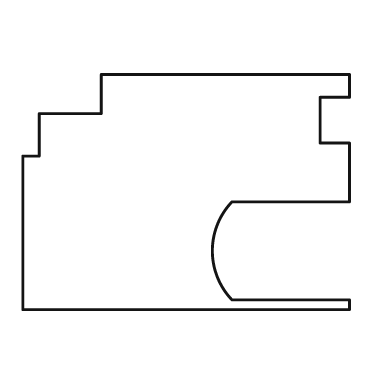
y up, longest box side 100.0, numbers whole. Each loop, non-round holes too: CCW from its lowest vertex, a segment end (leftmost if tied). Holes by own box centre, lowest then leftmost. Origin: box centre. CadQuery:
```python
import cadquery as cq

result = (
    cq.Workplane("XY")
    .moveTo(-50.0, -36.0)
    .lineTo(50.0, -36.0)
    .lineTo(50.0, -33.0)
    .lineTo(14.0, -33.0)
    .threePointArc((8.0, -18.0), (14.0, -3.0))
    .lineTo(50.0, -3.0)
    .lineTo(50.0, 15.0)
    .lineTo(41.0, 15.0)
    .lineTo(41.0, 29.0)
    .lineTo(50.0, 29.0)
    .lineTo(50.0, 36.0)
    .lineTo(-26.0, 36.0)
    .lineTo(-26.0, 24.0)
    .lineTo(-45.0, 24.0)
    .lineTo(-45.0, 11.0)
    .lineTo(-50.0, 11.0)
    .close()
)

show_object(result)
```